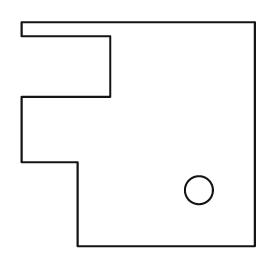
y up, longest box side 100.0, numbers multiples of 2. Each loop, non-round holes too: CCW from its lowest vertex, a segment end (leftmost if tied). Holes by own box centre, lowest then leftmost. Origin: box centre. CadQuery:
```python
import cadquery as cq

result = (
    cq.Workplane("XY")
    .moveTo(-26.0, -48.0)
    .lineTo(50.0, -48.0)
    .lineTo(50.0, 48.0)
    .lineTo(-50.0, 48.0)
    .lineTo(-50.0, 42.0)
    .lineTo(-12.0, 42.0)
    .lineTo(-12.0, 16.0)
    .lineTo(-50.0, 16.0)
    .lineTo(-50.0, -12.0)
    .lineTo(-26.0, -12.0)
    .close()
    .moveTo(26.0, -24.0)
    .circle(6.0)
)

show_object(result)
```